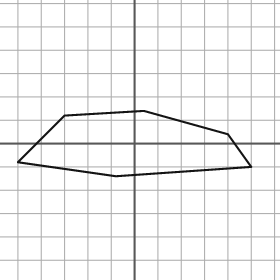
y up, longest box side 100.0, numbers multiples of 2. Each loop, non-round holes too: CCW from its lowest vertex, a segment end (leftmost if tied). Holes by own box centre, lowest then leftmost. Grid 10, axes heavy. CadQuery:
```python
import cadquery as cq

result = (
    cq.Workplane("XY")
    .moveTo(-8.0, -14.0)
    .lineTo(50.0, -10.0)
    .lineTo(40.0, 4.0)
    .lineTo(4.0, 14.0)
    .lineTo(-30.0, 12.0)
    .lineTo(-50.0, -8.0)
    .close()
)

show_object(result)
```